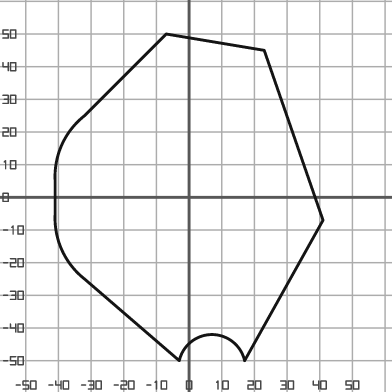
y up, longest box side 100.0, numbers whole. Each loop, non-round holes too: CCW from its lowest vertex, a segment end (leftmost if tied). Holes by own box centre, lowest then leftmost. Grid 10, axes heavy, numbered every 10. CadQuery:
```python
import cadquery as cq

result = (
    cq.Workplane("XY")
    .moveTo(-3.0, -50.0)
    .threePointArc((7.0, -42.0), (17.0, -50.0))
    .lineTo(41.0, -7.0)
    .lineTo(23.0, 45.0)
    .lineTo(-7.0, 50.0)
    .lineTo(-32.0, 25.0)
    .threePointArc((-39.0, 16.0), (-41.0, 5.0))
    .lineTo(-41.0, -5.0)
    .threePointArc((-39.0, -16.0), (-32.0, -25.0))
    .close()
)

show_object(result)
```